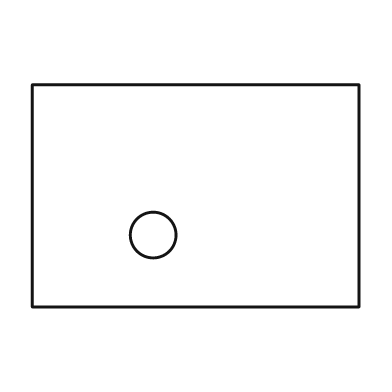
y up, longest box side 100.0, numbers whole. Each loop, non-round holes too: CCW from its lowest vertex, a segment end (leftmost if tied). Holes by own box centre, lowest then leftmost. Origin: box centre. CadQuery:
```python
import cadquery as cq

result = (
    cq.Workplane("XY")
    .moveTo(-50.0, -34.0)
    .lineTo(50.0, -34.0)
    .lineTo(50.0, 34.0)
    .lineTo(-50.0, 34.0)
    .close()
    .moveTo(-13.0, -12.0)
    .circle(7.0)
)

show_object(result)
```